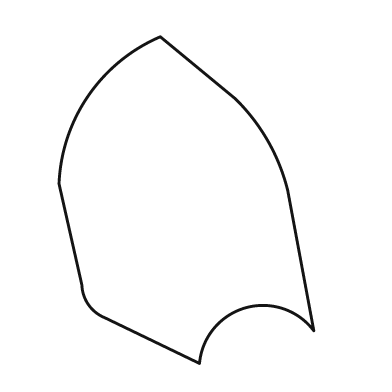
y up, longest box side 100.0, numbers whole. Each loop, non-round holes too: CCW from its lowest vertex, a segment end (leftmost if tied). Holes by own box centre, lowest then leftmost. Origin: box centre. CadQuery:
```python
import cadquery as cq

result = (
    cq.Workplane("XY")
    .moveTo(4.0, -50.0)
    .threePointArc((18.0, -33.0), (39.0, -40.0))
    .lineTo(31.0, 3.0)
    .threePointArc((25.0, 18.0), (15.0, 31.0))
    .lineTo(-8.0, 50.0)
    .threePointArc((-30.0, 32.0), (-39.0, 5.0))
    .lineTo(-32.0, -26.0)
    .threePointArc((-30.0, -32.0), (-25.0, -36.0))
    .close()
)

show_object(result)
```